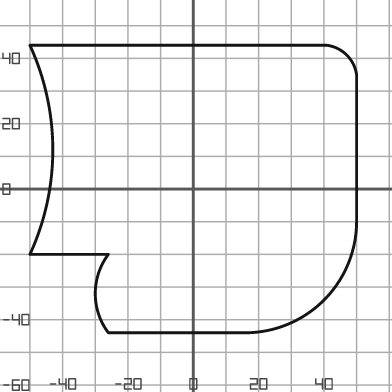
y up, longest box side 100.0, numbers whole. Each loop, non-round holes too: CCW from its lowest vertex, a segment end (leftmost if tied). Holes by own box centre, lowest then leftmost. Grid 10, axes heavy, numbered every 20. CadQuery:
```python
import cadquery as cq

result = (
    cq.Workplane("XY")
    .moveTo(-26.0, -44.0)
    .lineTo(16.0, -44.0)
    .threePointArc((40.0, -34.0), (50.0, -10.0))
    .lineTo(50.0, 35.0)
    .threePointArc((47.0, 41.0), (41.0, 44.0))
    .lineTo(-50.0, 44.0)
    .threePointArc((-43.0, 12.0), (-50.0, -20.0))
    .lineTo(-26.0, -20.0)
    .threePointArc((-30.0, -32.0), (-26.0, -44.0))
    .close()
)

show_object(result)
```